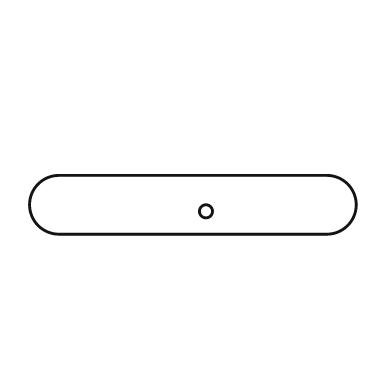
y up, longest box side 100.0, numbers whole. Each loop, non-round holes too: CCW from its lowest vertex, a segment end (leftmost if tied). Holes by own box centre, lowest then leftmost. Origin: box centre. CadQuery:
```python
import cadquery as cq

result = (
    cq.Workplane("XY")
    .moveTo(-41.0, -9.0)
    .lineTo(41.0, -9.0)
    .threePointArc((50.0, 0.0), (41.0, 9.0))
    .lineTo(-41.0, 9.0)
    .threePointArc((-50.0, 0.0), (-41.0, -9.0))
    .close()
    .moveTo(4.0, -2.0)
    .circle(2.0)
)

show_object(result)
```